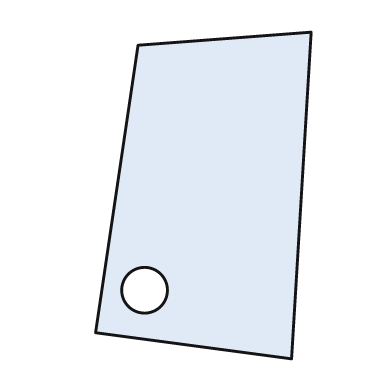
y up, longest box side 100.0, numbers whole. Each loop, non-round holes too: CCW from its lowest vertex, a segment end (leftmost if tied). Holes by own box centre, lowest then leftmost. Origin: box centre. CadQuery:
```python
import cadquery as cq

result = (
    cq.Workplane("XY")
    .moveTo(27.0, -50.0)
    .lineTo(33.0, 50.0)
    .lineTo(-20.0, 46.0)
    .lineTo(-33.0, -42.0)
    .close()
    .moveTo(-18.0, -29.0)
    .circle(7.0)
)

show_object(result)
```